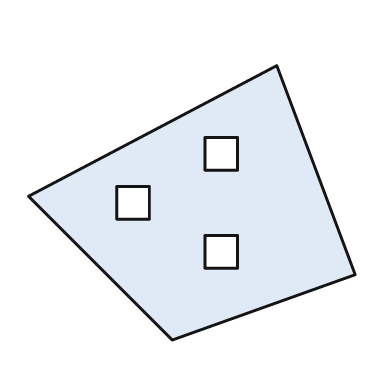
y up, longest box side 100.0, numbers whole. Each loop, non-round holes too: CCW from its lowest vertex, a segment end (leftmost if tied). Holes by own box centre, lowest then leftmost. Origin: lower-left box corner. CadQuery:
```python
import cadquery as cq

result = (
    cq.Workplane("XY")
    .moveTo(44.0, 0.0)
    .lineTo(100.0, 20.0)
    .lineTo(76.0, 84.0)
    .lineTo(0.0, 44.0)
    .close()
    .moveTo(54.0, 22.0)
    .lineTo(64.0, 22.0)
    .lineTo(64.0, 32.0)
    .lineTo(54.0, 32.0)
    .close()
    .moveTo(27.0, 37.0)
    .lineTo(37.0, 37.0)
    .lineTo(37.0, 47.0)
    .lineTo(27.0, 47.0)
    .close()
    .moveTo(54.0, 52.0)
    .lineTo(64.0, 52.0)
    .lineTo(64.0, 62.0)
    .lineTo(54.0, 62.0)
    .close()
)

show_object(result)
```